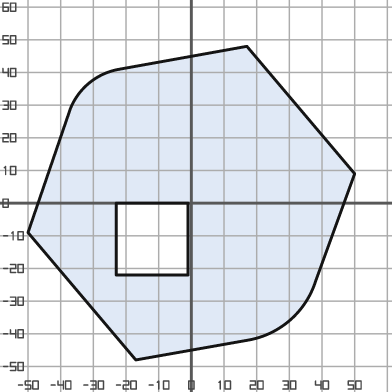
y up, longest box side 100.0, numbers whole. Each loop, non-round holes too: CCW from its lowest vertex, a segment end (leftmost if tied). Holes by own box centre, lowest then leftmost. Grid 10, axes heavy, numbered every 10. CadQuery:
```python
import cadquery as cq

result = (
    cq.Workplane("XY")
    .moveTo(-17.0, -48.0)
    .lineTo(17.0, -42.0)
    .threePointArc((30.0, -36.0), (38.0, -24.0))
    .lineTo(50.0, 9.0)
    .lineTo(17.0, 48.0)
    .lineTo(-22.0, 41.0)
    .threePointArc((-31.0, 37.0), (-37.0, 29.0))
    .lineTo(-50.0, -9.0)
    .close()
    .moveTo(-23.0, -22.0)
    .lineTo(-1.0, -22.0)
    .lineTo(-1.0, 0.0)
    .lineTo(-23.0, 0.0)
    .close()
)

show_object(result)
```